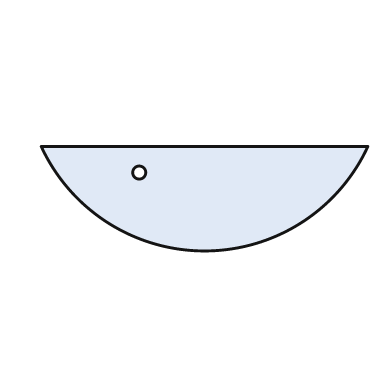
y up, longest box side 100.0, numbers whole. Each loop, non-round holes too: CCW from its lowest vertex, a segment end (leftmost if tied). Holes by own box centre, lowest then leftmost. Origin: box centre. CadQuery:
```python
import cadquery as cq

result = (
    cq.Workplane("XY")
    .moveTo(-50.0, 16.0)
    .threePointArc((0.0, -16.0), (50.0, 16.0))
    .close()
    .moveTo(-20.0, 8.0)
    .circle(2.0)
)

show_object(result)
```